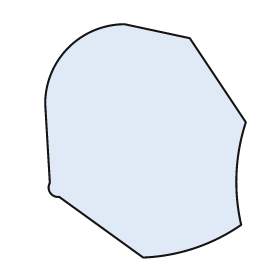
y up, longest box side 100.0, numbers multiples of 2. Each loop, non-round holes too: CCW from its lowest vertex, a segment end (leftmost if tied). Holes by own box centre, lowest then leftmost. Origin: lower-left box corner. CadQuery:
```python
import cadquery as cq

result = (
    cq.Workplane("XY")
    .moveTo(42.0, 0.0)
    .threePointArc((64.0, 4.0), (84.0, 14.0))
    .threePointArc((82.0, 36.0), (86.0, 58.0))
    .lineTo(62.0, 94.0)
    .lineTo(34.0, 100.0)
    .threePointArc((10.0, 90.0), (0.0, 66.0))
    .lineTo(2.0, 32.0)
    .threePointArc((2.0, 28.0), (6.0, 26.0))
    .close()
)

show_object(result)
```